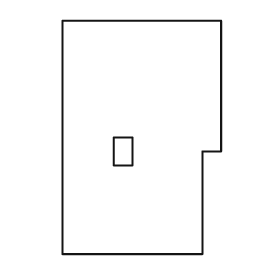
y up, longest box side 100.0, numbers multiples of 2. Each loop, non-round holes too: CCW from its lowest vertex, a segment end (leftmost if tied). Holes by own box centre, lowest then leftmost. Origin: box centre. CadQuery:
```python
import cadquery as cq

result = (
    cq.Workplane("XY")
    .moveTo(-34.0, -50.0)
    .lineTo(26.0, -50.0)
    .lineTo(26.0, -6.0)
    .lineTo(34.0, -6.0)
    .lineTo(34.0, 50.0)
    .lineTo(-34.0, 50.0)
    .close()
    .moveTo(-12.0, -12.0)
    .lineTo(-4.0, -12.0)
    .lineTo(-4.0, 0.0)
    .lineTo(-12.0, 0.0)
    .close()
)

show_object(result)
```